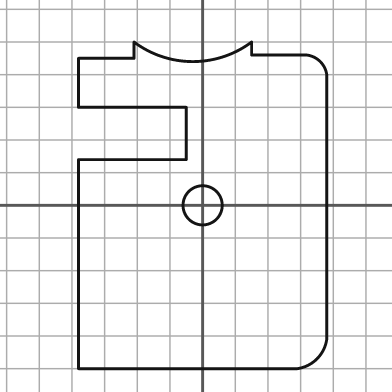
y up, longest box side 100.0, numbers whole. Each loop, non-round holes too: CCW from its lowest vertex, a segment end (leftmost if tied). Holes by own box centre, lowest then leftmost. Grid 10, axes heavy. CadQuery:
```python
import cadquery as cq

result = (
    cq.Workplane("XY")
    .moveTo(-38.0, -50.0)
    .lineTo(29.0, -50.0)
    .threePointArc((35.0, -47.0), (38.0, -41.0))
    .lineTo(38.0, 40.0)
    .threePointArc((36.0, 44.0), (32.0, 46.0))
    .lineTo(15.0, 46.0)
    .lineTo(15.0, 50.0)
    .threePointArc((-3.0, 44.0), (-21.0, 50.0))
    .lineTo(-21.0, 45.0)
    .lineTo(-38.0, 45.0)
    .lineTo(-38.0, 30.0)
    .lineTo(-5.0, 30.0)
    .lineTo(-5.0, 14.0)
    .lineTo(-38.0, 14.0)
    .close()
    .moveTo(0.0, 0.0)
    .circle(6.0)
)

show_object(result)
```